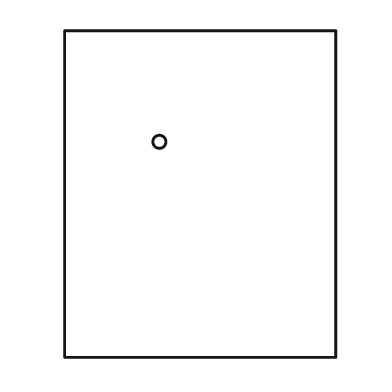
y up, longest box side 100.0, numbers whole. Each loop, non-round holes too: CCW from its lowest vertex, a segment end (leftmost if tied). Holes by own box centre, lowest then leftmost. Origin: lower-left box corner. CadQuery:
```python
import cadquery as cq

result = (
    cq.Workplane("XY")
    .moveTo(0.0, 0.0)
    .lineTo(83.0, 0.0)
    .lineTo(83.0, 100.0)
    .lineTo(0.0, 100.0)
    .close()
    .moveTo(29.0, 66.0)
    .circle(2.0)
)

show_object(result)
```